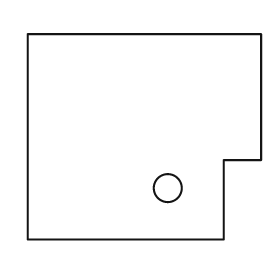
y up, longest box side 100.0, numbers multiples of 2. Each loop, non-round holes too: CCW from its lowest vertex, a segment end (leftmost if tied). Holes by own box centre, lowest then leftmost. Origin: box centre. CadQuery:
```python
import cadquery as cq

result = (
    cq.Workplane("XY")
    .moveTo(-50.0, -44.0)
    .lineTo(34.0, -44.0)
    .lineTo(34.0, -10.0)
    .lineTo(50.0, -10.0)
    .lineTo(50.0, 44.0)
    .lineTo(-50.0, 44.0)
    .close()
    .moveTo(10.0, -22.0)
    .circle(6.0)
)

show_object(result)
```